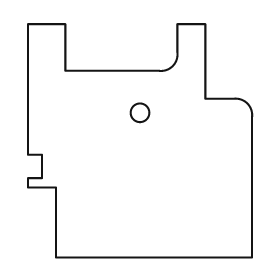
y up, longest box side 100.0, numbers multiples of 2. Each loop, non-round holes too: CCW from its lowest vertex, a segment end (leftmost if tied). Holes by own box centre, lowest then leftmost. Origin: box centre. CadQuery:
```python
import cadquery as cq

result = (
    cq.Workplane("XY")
    .moveTo(-36.0, -50.0)
    .lineTo(48.0, -50.0)
    .lineTo(48.0, 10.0)
    .threePointArc((46.0, 16.0), (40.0, 18.0))
    .lineTo(28.0, 18.0)
    .lineTo(28.0, 50.0)
    .lineTo(16.0, 50.0)
    .lineTo(16.0, 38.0)
    .threePointArc((14.0, 32.0), (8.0, 30.0))
    .lineTo(-32.0, 30.0)
    .lineTo(-32.0, 50.0)
    .lineTo(-48.0, 50.0)
    .lineTo(-48.0, -6.0)
    .lineTo(-42.0, -6.0)
    .lineTo(-42.0, -16.0)
    .lineTo(-48.0, -16.0)
    .lineTo(-48.0, -20.0)
    .lineTo(-36.0, -20.0)
    .close()
    .moveTo(0.0, 12.0)
    .circle(4.0)
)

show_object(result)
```